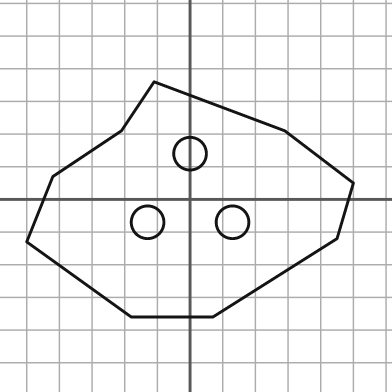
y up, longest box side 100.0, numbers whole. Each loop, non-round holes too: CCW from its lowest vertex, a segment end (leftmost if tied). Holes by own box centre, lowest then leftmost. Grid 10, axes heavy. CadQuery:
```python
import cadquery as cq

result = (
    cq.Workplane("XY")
    .moveTo(-18.0, -36.0)
    .lineTo(7.0, -36.0)
    .lineTo(45.0, -12.0)
    .lineTo(50.0, 5.0)
    .lineTo(29.0, 21.0)
    .lineTo(-11.0, 36.0)
    .lineTo(-21.0, 21.0)
    .lineTo(-42.0, 7.0)
    .lineTo(-50.0, -13.0)
    .close()
    .moveTo(-13.0, -7.0)
    .circle(5.0)
    .moveTo(13.0, -7.0)
    .circle(5.0)
    .moveTo(0.0, 14.0)
    .circle(5.0)
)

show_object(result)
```